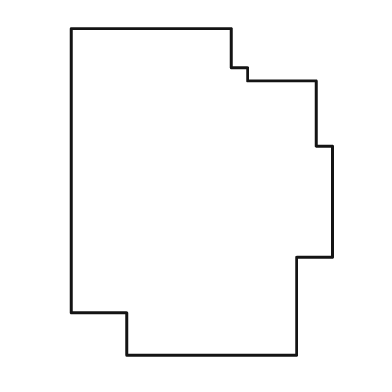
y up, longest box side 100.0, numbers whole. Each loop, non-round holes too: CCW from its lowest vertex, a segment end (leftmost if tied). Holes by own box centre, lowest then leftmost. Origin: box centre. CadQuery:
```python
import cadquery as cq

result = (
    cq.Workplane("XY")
    .moveTo(-23.0, -50.0)
    .lineTo(29.0, -50.0)
    .lineTo(29.0, -20.0)
    .lineTo(40.0, -20.0)
    .lineTo(40.0, 14.0)
    .lineTo(35.0, 14.0)
    .lineTo(35.0, 34.0)
    .lineTo(14.0, 34.0)
    .lineTo(14.0, 38.0)
    .lineTo(9.0, 38.0)
    .lineTo(9.0, 50.0)
    .lineTo(-40.0, 50.0)
    .lineTo(-40.0, -37.0)
    .lineTo(-23.0, -37.0)
    .close()
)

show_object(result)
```